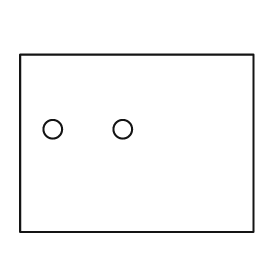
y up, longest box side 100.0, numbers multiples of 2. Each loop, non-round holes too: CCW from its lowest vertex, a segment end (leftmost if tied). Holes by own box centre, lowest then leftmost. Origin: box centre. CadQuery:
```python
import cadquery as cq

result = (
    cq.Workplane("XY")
    .moveTo(-50.0, -38.0)
    .lineTo(50.0, -38.0)
    .lineTo(50.0, 38.0)
    .lineTo(-50.0, 38.0)
    .close()
    .moveTo(-36.0, 6.0)
    .circle(4.0)
    .moveTo(-6.0, 6.0)
    .circle(4.0)
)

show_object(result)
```